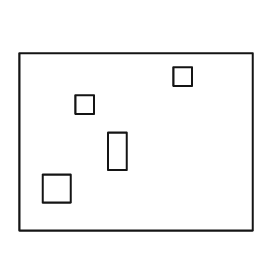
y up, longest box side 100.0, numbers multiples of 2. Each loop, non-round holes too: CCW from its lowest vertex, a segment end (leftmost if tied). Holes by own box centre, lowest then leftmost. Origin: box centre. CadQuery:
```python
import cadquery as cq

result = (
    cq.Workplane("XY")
    .moveTo(-50.0, -38.0)
    .lineTo(50.0, -38.0)
    .lineTo(50.0, 38.0)
    .lineTo(-50.0, 38.0)
    .close()
    .moveTo(-40.0, -26.0)
    .lineTo(-28.0, -26.0)
    .lineTo(-28.0, -14.0)
    .lineTo(-40.0, -14.0)
    .close()
    .moveTo(-12.0, -12.0)
    .lineTo(-4.0, -12.0)
    .lineTo(-4.0, 4.0)
    .lineTo(-12.0, 4.0)
    .close()
    .moveTo(-26.0, 12.0)
    .lineTo(-18.0, 12.0)
    .lineTo(-18.0, 20.0)
    .lineTo(-26.0, 20.0)
    .close()
    .moveTo(16.0, 24.0)
    .lineTo(24.0, 24.0)
    .lineTo(24.0, 32.0)
    .lineTo(16.0, 32.0)
    .close()
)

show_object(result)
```